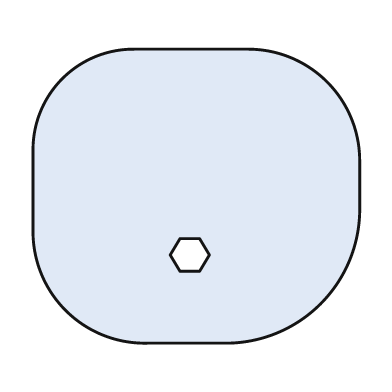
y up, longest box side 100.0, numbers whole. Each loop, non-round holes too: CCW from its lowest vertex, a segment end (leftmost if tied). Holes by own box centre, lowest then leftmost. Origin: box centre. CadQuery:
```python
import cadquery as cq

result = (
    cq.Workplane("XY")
    .moveTo(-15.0, -45.0)
    .lineTo(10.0, -45.0)
    .threePointArc((38.0, -33.0), (50.0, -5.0))
    .lineTo(50.0, 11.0)
    .threePointArc((40.0, 35.0), (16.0, 45.0))
    .lineTo(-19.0, 45.0)
    .threePointArc((-41.0, 36.0), (-50.0, 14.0))
    .lineTo(-50.0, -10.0)
    .threePointArc((-40.0, -35.0), (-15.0, -45.0))
    .close()
    .moveTo(-5.0, -23.0)
    .lineTo(1.0, -23.0)
    .lineTo(4.0, -18.0)
    .lineTo(1.0, -13.0)
    .lineTo(-5.0, -13.0)
    .lineTo(-8.0, -18.0)
    .close()
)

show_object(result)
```